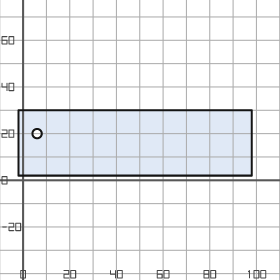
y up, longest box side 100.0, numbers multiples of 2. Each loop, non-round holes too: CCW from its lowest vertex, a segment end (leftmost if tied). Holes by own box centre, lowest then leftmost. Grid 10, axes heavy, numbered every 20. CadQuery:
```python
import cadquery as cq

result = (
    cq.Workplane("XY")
    .moveTo(-2.0, 2.0)
    .lineTo(98.0, 2.0)
    .lineTo(98.0, 30.0)
    .lineTo(-2.0, 30.0)
    .close()
    .moveTo(6.0, 20.0)
    .circle(2.0)
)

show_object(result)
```